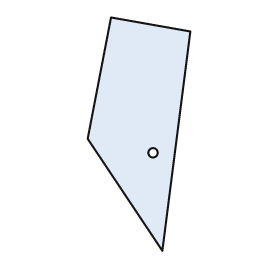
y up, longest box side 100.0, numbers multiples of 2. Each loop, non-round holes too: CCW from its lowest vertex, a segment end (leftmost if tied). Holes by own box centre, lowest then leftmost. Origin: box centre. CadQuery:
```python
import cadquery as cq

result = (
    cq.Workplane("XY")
    .moveTo(10.0, -50.0)
    .lineTo(22.0, 44.0)
    .lineTo(-12.0, 50.0)
    .lineTo(-22.0, -2.0)
    .close()
    .moveTo(6.0, -8.0)
    .circle(2.0)
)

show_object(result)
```